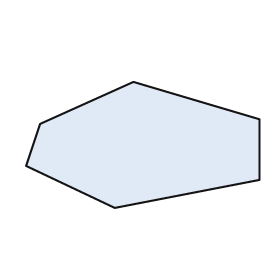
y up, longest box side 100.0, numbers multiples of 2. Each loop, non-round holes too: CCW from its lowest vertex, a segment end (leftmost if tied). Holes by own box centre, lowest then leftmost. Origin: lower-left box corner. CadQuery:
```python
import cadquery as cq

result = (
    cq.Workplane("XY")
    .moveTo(38.0, 0.0)
    .lineTo(100.0, 12.0)
    .lineTo(100.0, 38.0)
    .lineTo(46.0, 54.0)
    .lineTo(6.0, 36.0)
    .lineTo(0.0, 18.0)
    .close()
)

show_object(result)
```